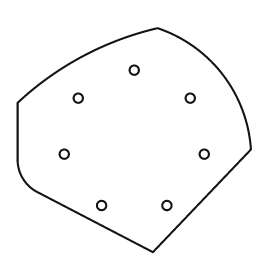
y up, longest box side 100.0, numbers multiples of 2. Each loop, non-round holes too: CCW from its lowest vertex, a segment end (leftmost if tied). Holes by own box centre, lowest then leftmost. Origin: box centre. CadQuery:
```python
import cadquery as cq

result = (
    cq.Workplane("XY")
    .moveTo(8.0, -48.0)
    .lineTo(50.0, -4.0)
    .threePointArc((38.0, 28.0), (10.0, 48.0))
    .threePointArc((-22.0, 36.0), (-50.0, 16.0))
    .lineTo(-50.0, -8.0)
    .threePointArc((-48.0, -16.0), (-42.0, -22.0))
    .close()
    .moveTo(-14.0, -28.0)
    .circle(2.0)
    .moveTo(14.0, -28.0)
    .circle(2.0)
    .moveTo(-30.0, -6.0)
    .circle(2.0)
    .moveTo(30.0, -6.0)
    .circle(2.0)
    .moveTo(-24.0, 18.0)
    .circle(2.0)
    .moveTo(24.0, 18.0)
    .circle(2.0)
    .moveTo(0.0, 30.0)
    .circle(2.0)
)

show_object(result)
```